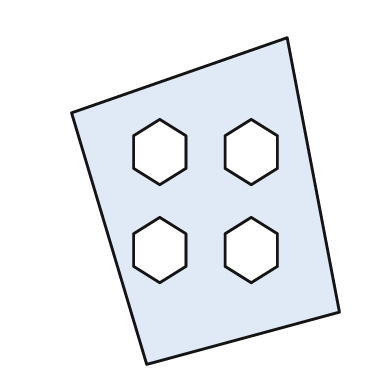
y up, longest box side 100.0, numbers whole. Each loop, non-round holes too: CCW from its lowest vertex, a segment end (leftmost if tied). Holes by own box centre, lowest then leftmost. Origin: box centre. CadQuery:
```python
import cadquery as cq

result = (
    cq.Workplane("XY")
    .moveTo(-18.0, -50.0)
    .lineTo(41.0, -34.0)
    .lineTo(25.0, 50.0)
    .lineTo(-41.0, 27.0)
    .close()
    .moveTo(-14.0, -25.0)
    .lineTo(-6.0, -20.0)
    .lineTo(-6.0, -10.0)
    .lineTo(-14.0, -5.0)
    .lineTo(-22.0, -10.0)
    .lineTo(-22.0, -20.0)
    .close()
    .moveTo(14.0, -25.0)
    .lineTo(22.0, -20.0)
    .lineTo(22.0, -10.0)
    .lineTo(14.0, -5.0)
    .lineTo(6.0, -10.0)
    .lineTo(6.0, -20.0)
    .close()
    .moveTo(-14.0, 5.0)
    .lineTo(-6.0, 10.0)
    .lineTo(-6.0, 20.0)
    .lineTo(-14.0, 25.0)
    .lineTo(-22.0, 20.0)
    .lineTo(-22.0, 10.0)
    .close()
    .moveTo(14.0, 5.0)
    .lineTo(22.0, 10.0)
    .lineTo(22.0, 20.0)
    .lineTo(14.0, 25.0)
    .lineTo(6.0, 20.0)
    .lineTo(6.0, 10.0)
    .close()
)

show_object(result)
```